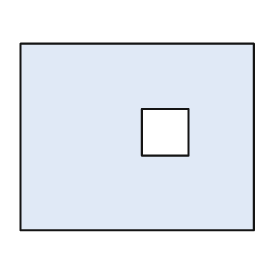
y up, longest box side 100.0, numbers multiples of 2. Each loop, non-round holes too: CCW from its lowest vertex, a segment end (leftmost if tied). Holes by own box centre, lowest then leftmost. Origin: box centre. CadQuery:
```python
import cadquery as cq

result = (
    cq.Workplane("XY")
    .moveTo(-50.0, -40.0)
    .lineTo(50.0, -40.0)
    .lineTo(50.0, 40.0)
    .lineTo(-50.0, 40.0)
    .close()
    .moveTo(2.0, -8.0)
    .lineTo(22.0, -8.0)
    .lineTo(22.0, 12.0)
    .lineTo(2.0, 12.0)
    .close()
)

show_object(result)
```